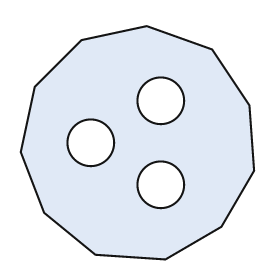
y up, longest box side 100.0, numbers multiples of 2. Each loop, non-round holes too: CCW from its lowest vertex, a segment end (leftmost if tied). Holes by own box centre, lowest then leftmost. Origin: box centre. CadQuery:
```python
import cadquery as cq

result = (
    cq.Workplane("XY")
    .moveTo(12.0, -50.0)
    .lineTo(36.0, -36.0)
    .lineTo(50.0, -12.0)
    .lineTo(48.0, 16.0)
    .lineTo(32.0, 40.0)
    .lineTo(4.0, 50.0)
    .lineTo(-24.0, 44.0)
    .lineTo(-44.0, 24.0)
    .lineTo(-50.0, -4.0)
    .lineTo(-40.0, -30.0)
    .lineTo(-18.0, -48.0)
    .close()
    .moveTo(10.0, -18.0)
    .circle(10.0)
    .moveTo(-20.0, 0.0)
    .circle(10.0)
    .moveTo(10.0, 18.0)
    .circle(10.0)
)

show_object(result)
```